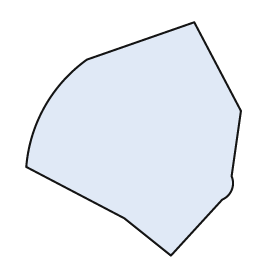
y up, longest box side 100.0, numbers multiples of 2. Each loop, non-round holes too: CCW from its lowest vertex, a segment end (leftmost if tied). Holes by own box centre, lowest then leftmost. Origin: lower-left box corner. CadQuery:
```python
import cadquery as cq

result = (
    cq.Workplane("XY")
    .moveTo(62.0, 0.0)
    .lineTo(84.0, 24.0)
    .threePointArc((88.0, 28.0), (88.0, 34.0))
    .lineTo(92.0, 62.0)
    .lineTo(72.0, 100.0)
    .lineTo(26.0, 84.0)
    .threePointArc((8.0, 64.0), (0.0, 38.0))
    .lineTo(42.0, 16.0)
    .close()
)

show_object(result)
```